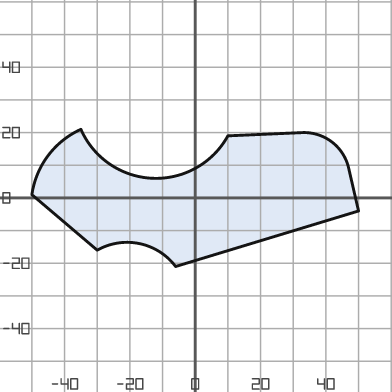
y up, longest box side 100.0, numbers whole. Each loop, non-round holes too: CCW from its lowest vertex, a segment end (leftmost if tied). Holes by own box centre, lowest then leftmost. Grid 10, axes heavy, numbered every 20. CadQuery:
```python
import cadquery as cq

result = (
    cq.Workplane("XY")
    .moveTo(-6.0, -21.0)
    .lineTo(50.0, -4.0)
    .lineTo(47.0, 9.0)
    .threePointArc((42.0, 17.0), (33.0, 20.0))
    .lineTo(10.0, 19.0)
    .threePointArc((-13.0, 6.0), (-35.0, 21.0))
    .threePointArc((-45.0, 13.0), (-50.0, 1.0))
    .lineTo(-30.0, -16.0)
    .threePointArc((-17.0, -14.0), (-6.0, -21.0))
    .close()
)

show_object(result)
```